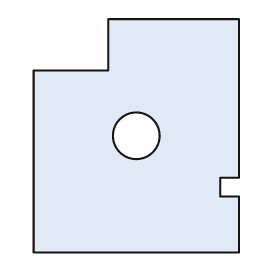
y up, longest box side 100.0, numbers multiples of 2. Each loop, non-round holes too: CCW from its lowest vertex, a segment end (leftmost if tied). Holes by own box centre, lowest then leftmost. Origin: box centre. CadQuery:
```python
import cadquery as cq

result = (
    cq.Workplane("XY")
    .moveTo(-44.0, -50.0)
    .lineTo(44.0, -50.0)
    .lineTo(44.0, -26.0)
    .lineTo(36.0, -26.0)
    .lineTo(36.0, -18.0)
    .lineTo(44.0, -18.0)
    .lineTo(44.0, 50.0)
    .lineTo(-12.0, 50.0)
    .lineTo(-12.0, 28.0)
    .lineTo(-44.0, 28.0)
    .close()
    .moveTo(0.0, 0.0)
    .circle(10.0)
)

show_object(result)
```